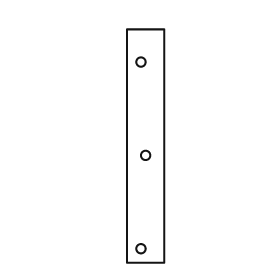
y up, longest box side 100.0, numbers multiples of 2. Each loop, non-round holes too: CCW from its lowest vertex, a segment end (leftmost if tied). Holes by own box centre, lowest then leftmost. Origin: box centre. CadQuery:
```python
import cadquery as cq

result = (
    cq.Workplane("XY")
    .moveTo(-8.0, -50.0)
    .lineTo(8.0, -50.0)
    .lineTo(8.0, 50.0)
    .lineTo(-8.0, 50.0)
    .close()
    .moveTo(-2.0, -44.0)
    .circle(2.0)
    .moveTo(0.0, -4.0)
    .circle(2.0)
    .moveTo(-2.0, 36.0)
    .circle(2.0)
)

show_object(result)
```